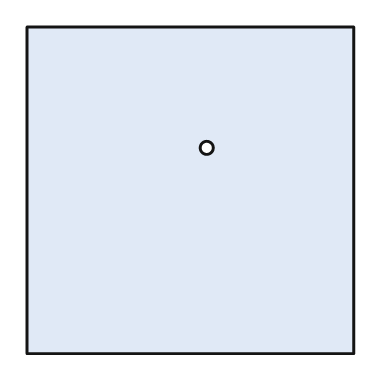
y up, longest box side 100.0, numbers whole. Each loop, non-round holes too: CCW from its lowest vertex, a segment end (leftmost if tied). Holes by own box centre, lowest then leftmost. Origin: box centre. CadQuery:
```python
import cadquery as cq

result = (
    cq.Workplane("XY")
    .moveTo(-50.0, -50.0)
    .lineTo(50.0, -50.0)
    .lineTo(50.0, 50.0)
    .lineTo(-50.0, 50.0)
    .close()
    .moveTo(5.0, 13.0)
    .circle(2.0)
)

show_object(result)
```